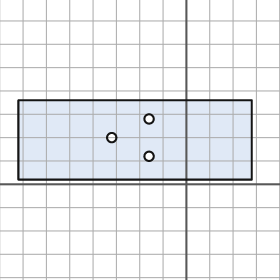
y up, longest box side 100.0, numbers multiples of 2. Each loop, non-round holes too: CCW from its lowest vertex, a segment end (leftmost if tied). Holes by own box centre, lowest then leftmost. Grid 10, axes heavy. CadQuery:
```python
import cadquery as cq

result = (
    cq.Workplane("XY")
    .moveTo(-72.0, 2.0)
    .lineTo(28.0, 2.0)
    .lineTo(28.0, 36.0)
    .lineTo(-72.0, 36.0)
    .close()
    .moveTo(-16.0, 12.0)
    .circle(2.0)
    .moveTo(-32.0, 20.0)
    .circle(2.0)
    .moveTo(-16.0, 28.0)
    .circle(2.0)
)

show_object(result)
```